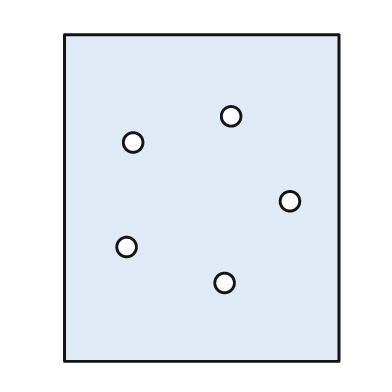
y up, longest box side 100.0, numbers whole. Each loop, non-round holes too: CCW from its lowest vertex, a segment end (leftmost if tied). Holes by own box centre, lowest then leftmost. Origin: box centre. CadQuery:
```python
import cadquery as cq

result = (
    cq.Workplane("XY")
    .moveTo(-42.0, -50.0)
    .lineTo(42.0, -50.0)
    .lineTo(42.0, 50.0)
    .lineTo(-42.0, 50.0)
    .close()
    .moveTo(7.0, -26.0)
    .circle(3.0)
    .moveTo(-23.0, -15.0)
    .circle(3.0)
    .moveTo(27.0, -1.0)
    .circle(3.0)
    .moveTo(-21.0, 17.0)
    .circle(3.0)
    .moveTo(9.0, 25.0)
    .circle(3.0)
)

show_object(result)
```